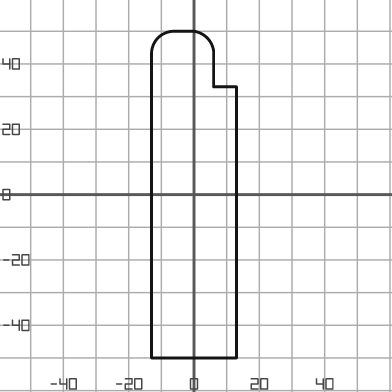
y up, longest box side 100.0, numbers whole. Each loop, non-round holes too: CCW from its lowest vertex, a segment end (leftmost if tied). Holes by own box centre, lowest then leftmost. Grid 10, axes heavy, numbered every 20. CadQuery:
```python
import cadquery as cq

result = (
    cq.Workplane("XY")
    .moveTo(-13.0, -50.0)
    .lineTo(13.0, -50.0)
    .lineTo(13.0, 33.0)
    .lineTo(6.0, 33.0)
    .lineTo(6.0, 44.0)
    .threePointArc((4.0, 48.0), (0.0, 50.0))
    .lineTo(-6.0, 50.0)
    .threePointArc((-11.0, 48.0), (-13.0, 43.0))
    .close()
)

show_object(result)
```